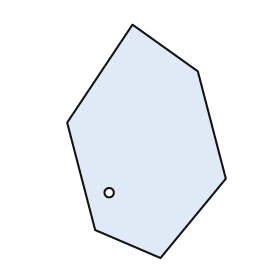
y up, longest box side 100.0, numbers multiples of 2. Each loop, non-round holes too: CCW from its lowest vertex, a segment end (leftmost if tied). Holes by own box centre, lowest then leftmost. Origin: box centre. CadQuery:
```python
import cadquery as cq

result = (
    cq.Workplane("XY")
    .moveTo(6.0, -50.0)
    .lineTo(34.0, -16.0)
    .lineTo(22.0, 30.0)
    .lineTo(-6.0, 50.0)
    .lineTo(-34.0, 8.0)
    .lineTo(-22.0, -38.0)
    .close()
    .moveTo(-16.0, -22.0)
    .circle(2.0)
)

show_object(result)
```